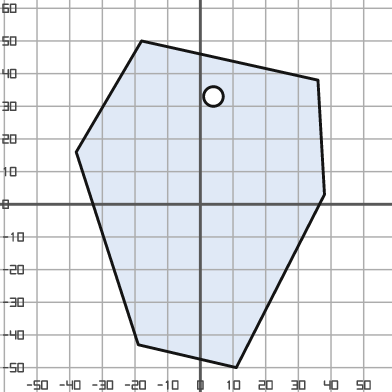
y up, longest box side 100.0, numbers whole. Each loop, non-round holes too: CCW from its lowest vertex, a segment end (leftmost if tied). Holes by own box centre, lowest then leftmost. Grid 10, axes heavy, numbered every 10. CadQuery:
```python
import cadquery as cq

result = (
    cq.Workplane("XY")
    .moveTo(11.0, -50.0)
    .lineTo(38.0, 3.0)
    .lineTo(36.0, 38.0)
    .lineTo(-18.0, 50.0)
    .lineTo(-38.0, 16.0)
    .lineTo(-19.0, -43.0)
    .close()
    .moveTo(4.0, 33.0)
    .circle(3.0)
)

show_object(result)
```